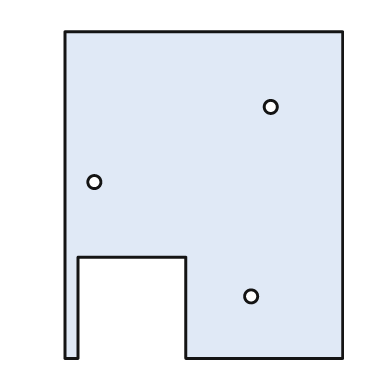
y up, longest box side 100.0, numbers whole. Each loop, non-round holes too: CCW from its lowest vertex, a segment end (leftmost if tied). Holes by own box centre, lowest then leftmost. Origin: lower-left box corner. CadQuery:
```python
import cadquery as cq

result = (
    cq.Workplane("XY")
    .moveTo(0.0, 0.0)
    .lineTo(4.0, 0.0)
    .lineTo(4.0, 31.0)
    .lineTo(37.0, 31.0)
    .lineTo(37.0, 0.0)
    .lineTo(85.0, 0.0)
    .lineTo(85.0, 100.0)
    .lineTo(0.0, 100.0)
    .close()
    .moveTo(57.0, 19.0)
    .circle(2.0)
    .moveTo(9.0, 54.0)
    .circle(2.0)
    .moveTo(63.0, 77.0)
    .circle(2.0)
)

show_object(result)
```